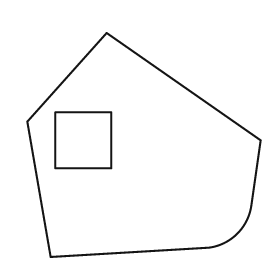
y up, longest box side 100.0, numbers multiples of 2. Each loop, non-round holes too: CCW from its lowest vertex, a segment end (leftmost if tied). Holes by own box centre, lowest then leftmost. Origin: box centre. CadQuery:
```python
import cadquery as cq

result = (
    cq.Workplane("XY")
    .moveTo(-40.0, -48.0)
    .lineTo(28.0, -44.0)
    .threePointArc((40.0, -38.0), (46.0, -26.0))
    .lineTo(50.0, 2.0)
    .lineTo(-16.0, 48.0)
    .lineTo(-50.0, 10.0)
    .close()
    .moveTo(-38.0, -10.0)
    .lineTo(-14.0, -10.0)
    .lineTo(-14.0, 14.0)
    .lineTo(-38.0, 14.0)
    .close()
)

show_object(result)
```